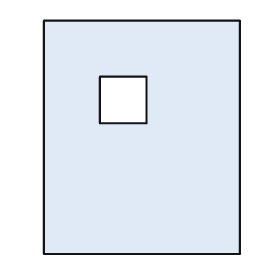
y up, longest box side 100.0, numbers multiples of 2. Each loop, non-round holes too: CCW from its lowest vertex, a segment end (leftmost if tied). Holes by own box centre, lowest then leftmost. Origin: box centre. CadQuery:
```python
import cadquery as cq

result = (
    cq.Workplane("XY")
    .moveTo(-42.0, -50.0)
    .lineTo(42.0, -50.0)
    .lineTo(42.0, 50.0)
    .lineTo(-42.0, 50.0)
    .close()
    .moveTo(-18.0, 6.0)
    .lineTo(2.0, 6.0)
    .lineTo(2.0, 26.0)
    .lineTo(-18.0, 26.0)
    .close()
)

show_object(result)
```